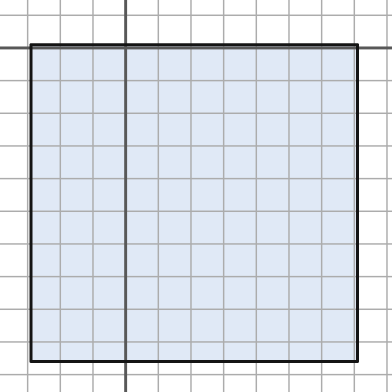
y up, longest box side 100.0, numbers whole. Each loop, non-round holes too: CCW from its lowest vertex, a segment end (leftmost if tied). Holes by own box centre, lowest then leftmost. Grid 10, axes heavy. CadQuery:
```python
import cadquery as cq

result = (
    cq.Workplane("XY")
    .moveTo(-29.0, -96.0)
    .lineTo(71.0, -96.0)
    .lineTo(71.0, 1.0)
    .lineTo(-29.0, 1.0)
    .close()
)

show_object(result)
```